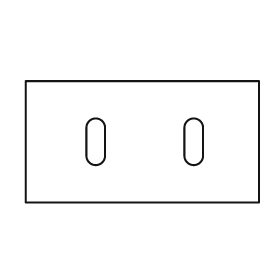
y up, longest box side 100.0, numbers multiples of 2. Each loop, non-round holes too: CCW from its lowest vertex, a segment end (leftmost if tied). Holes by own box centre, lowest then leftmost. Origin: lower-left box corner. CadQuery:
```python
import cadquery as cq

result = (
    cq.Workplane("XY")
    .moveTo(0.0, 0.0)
    .lineTo(100.0, 0.0)
    .lineTo(100.0, 52.0)
    .lineTo(0.0, 52.0)
    .close()
    .moveTo(26.0, 20.0)
    .threePointArc((30.0, 16.0), (34.0, 20.0))
    .lineTo(34.0, 32.0)
    .threePointArc((30.0, 36.0), (26.0, 32.0))
    .close()
    .moveTo(68.0, 20.0)
    .threePointArc((72.0, 16.0), (76.0, 20.0))
    .lineTo(76.0, 32.0)
    .threePointArc((72.0, 36.0), (68.0, 32.0))
    .close()
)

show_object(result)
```